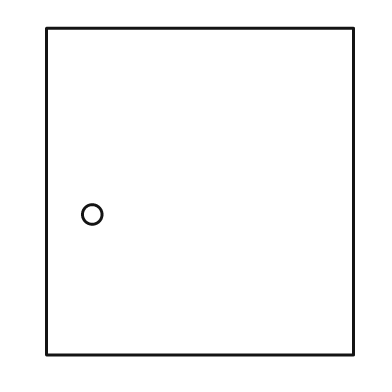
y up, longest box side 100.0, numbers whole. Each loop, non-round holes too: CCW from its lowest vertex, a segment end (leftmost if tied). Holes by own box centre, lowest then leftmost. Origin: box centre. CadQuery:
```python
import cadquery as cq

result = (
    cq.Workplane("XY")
    .moveTo(-47.0, -50.0)
    .lineTo(47.0, -50.0)
    .lineTo(47.0, 50.0)
    .lineTo(-47.0, 50.0)
    .close()
    .moveTo(-33.0, -7.0)
    .circle(3.0)
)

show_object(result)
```